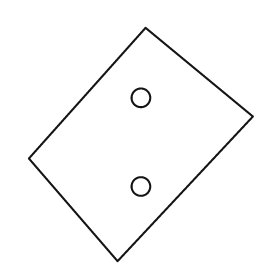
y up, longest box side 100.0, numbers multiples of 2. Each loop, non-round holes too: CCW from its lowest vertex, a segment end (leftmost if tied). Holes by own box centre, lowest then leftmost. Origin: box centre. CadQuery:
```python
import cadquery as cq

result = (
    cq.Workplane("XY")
    .moveTo(-10.0, -50.0)
    .lineTo(48.0, 12.0)
    .lineTo(2.0, 50.0)
    .lineTo(-48.0, -6.0)
    .close()
    .moveTo(0.0, -18.0)
    .circle(4.0)
    .moveTo(0.0, 20.0)
    .circle(4.0)
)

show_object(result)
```